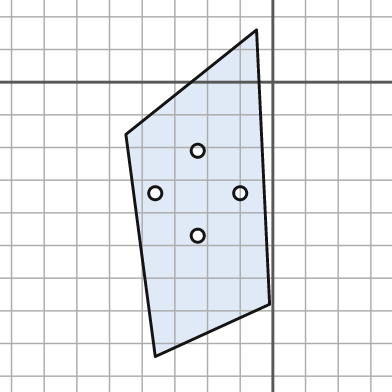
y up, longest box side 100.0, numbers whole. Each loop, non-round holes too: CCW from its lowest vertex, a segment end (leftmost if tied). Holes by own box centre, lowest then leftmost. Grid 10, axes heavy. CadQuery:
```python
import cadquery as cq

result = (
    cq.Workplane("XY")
    .moveTo(-36.0, -84.0)
    .lineTo(-1.0, -68.0)
    .lineTo(-5.0, 16.0)
    .lineTo(-45.0, -16.0)
    .close()
    .moveTo(-23.0, -47.0)
    .circle(2.0)
    .moveTo(-36.0, -34.0)
    .circle(2.0)
    .moveTo(-10.0, -34.0)
    .circle(2.0)
    .moveTo(-23.0, -21.0)
    .circle(2.0)
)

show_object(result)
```